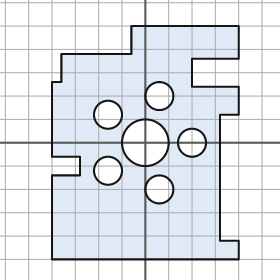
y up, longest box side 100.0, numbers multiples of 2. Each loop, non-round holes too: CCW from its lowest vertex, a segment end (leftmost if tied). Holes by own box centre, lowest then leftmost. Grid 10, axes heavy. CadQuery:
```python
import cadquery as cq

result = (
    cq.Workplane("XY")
    .moveTo(-40.0, -50.0)
    .lineTo(40.0, -50.0)
    .lineTo(40.0, -42.0)
    .lineTo(32.0, -42.0)
    .lineTo(32.0, 12.0)
    .lineTo(40.0, 12.0)
    .lineTo(40.0, 24.0)
    .lineTo(20.0, 24.0)
    .lineTo(20.0, 36.0)
    .lineTo(40.0, 36.0)
    .lineTo(40.0, 50.0)
    .lineTo(-6.0, 50.0)
    .lineTo(-6.0, 38.0)
    .lineTo(-36.0, 38.0)
    .lineTo(-36.0, 26.0)
    .lineTo(-40.0, 26.0)
    .lineTo(-40.0, -6.0)
    .lineTo(-28.0, -6.0)
    .lineTo(-28.0, -14.0)
    .lineTo(-40.0, -14.0)
    .close()
    .moveTo(6.0, -20.0)
    .circle(6.0)
    .moveTo(-16.0, -12.0)
    .circle(6.0)
    .moveTo(0.0, 0.0)
    .circle(10.0)
    .moveTo(20.0, 0.0)
    .circle(6.0)
    .moveTo(-16.0, 12.0)
    .circle(6.0)
    .moveTo(6.0, 20.0)
    .circle(6.0)
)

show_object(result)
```